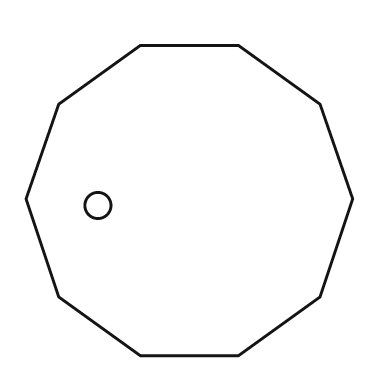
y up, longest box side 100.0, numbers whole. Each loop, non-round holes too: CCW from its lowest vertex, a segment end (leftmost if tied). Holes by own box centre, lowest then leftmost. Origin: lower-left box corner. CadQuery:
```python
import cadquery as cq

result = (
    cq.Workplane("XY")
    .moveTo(35.0, 0.0)
    .lineTo(65.0, 0.0)
    .lineTo(90.0, 18.0)
    .lineTo(100.0, 48.0)
    .lineTo(90.0, 77.0)
    .lineTo(65.0, 95.0)
    .lineTo(35.0, 95.0)
    .lineTo(10.0, 77.0)
    .lineTo(0.0, 48.0)
    .lineTo(10.0, 18.0)
    .close()
    .moveTo(22.0, 46.0)
    .circle(4.0)
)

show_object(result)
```